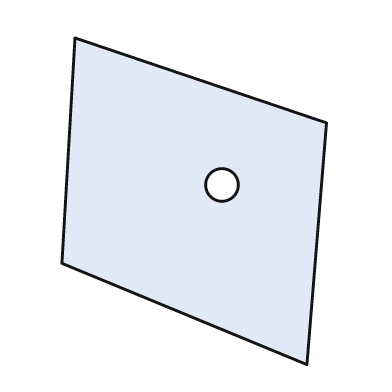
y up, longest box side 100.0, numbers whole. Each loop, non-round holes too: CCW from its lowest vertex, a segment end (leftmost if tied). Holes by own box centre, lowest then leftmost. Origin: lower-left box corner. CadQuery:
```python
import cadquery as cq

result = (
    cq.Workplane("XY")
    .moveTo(75.0, 0.0)
    .lineTo(81.0, 74.0)
    .lineTo(4.0, 100.0)
    .lineTo(0.0, 31.0)
    .close()
    .moveTo(49.0, 55.0)
    .circle(5.0)
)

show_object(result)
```